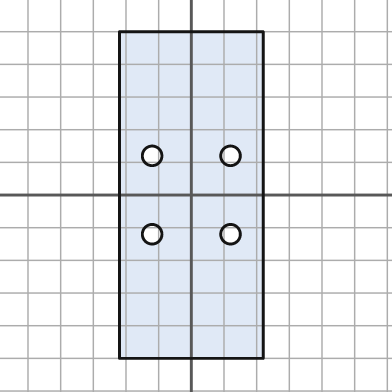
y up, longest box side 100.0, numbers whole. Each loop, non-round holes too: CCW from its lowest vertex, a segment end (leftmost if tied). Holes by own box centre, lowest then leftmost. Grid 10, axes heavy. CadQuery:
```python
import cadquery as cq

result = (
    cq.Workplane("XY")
    .moveTo(-22.0, -50.0)
    .lineTo(22.0, -50.0)
    .lineTo(22.0, 50.0)
    .lineTo(-22.0, 50.0)
    .close()
    .moveTo(-12.0, -12.0)
    .circle(3.0)
    .moveTo(12.0, -12.0)
    .circle(3.0)
    .moveTo(-12.0, 12.0)
    .circle(3.0)
    .moveTo(12.0, 12.0)
    .circle(3.0)
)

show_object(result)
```